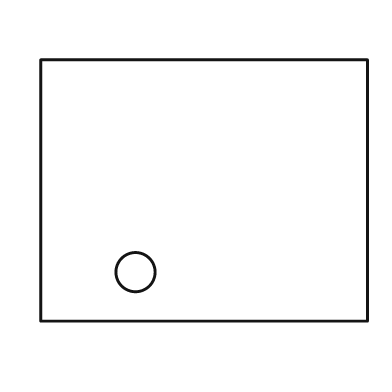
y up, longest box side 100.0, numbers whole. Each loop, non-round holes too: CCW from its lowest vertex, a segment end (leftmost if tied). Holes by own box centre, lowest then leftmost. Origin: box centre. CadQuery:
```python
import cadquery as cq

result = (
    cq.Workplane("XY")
    .moveTo(-50.0, -40.0)
    .lineTo(50.0, -40.0)
    .lineTo(50.0, 40.0)
    .lineTo(-50.0, 40.0)
    .close()
    .moveTo(-21.0, -25.0)
    .circle(6.0)
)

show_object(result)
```